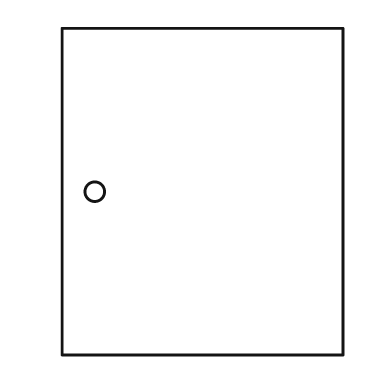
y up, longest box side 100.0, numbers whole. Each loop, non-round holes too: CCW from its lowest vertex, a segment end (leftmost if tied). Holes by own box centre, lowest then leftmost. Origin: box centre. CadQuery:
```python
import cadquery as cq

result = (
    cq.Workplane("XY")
    .moveTo(-43.0, -50.0)
    .lineTo(43.0, -50.0)
    .lineTo(43.0, 50.0)
    .lineTo(-43.0, 50.0)
    .close()
    .moveTo(-33.0, 0.0)
    .circle(3.0)
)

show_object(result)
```